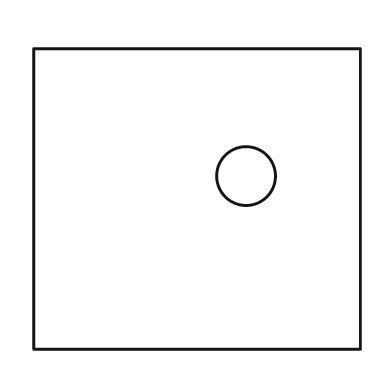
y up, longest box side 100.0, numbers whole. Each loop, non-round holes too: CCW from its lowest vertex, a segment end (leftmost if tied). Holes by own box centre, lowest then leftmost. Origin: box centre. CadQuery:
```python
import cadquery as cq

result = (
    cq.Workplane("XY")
    .moveTo(-50.0, -46.0)
    .lineTo(50.0, -46.0)
    .lineTo(50.0, 46.0)
    .lineTo(-50.0, 46.0)
    .close()
    .moveTo(15.0, 7.0)
    .circle(9.0)
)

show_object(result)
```